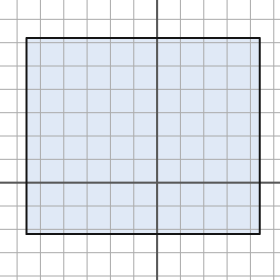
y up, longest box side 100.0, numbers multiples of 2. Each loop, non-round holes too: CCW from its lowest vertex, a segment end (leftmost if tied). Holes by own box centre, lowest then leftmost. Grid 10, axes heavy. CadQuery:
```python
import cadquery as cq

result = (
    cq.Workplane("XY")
    .moveTo(-56.0, -22.0)
    .lineTo(44.0, -22.0)
    .lineTo(44.0, 62.0)
    .lineTo(-56.0, 62.0)
    .close()
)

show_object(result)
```